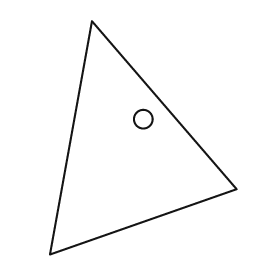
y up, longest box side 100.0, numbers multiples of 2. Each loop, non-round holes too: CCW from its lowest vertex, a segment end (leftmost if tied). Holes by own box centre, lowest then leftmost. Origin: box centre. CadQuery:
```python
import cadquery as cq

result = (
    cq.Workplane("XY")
    .moveTo(-40.0, -50.0)
    .lineTo(40.0, -22.0)
    .lineTo(-22.0, 50.0)
    .close()
    .moveTo(0.0, 8.0)
    .circle(4.0)
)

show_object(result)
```